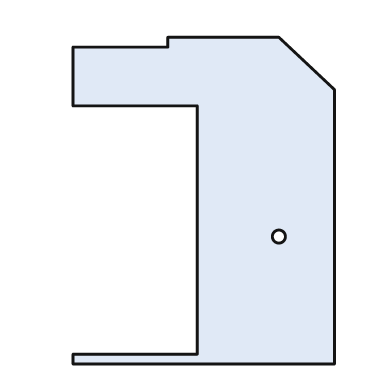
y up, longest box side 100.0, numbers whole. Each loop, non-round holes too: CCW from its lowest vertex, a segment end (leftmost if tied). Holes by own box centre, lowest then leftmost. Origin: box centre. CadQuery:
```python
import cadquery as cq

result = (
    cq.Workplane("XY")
    .moveTo(-40.0, -50.0)
    .lineTo(40.0, -50.0)
    .lineTo(40.0, 34.0)
    .lineTo(23.0, 50.0)
    .lineTo(-11.0, 50.0)
    .lineTo(-11.0, 47.0)
    .lineTo(-40.0, 47.0)
    .lineTo(-40.0, 29.0)
    .lineTo(-2.0, 29.0)
    .lineTo(-2.0, -47.0)
    .lineTo(-40.0, -47.0)
    .close()
    .moveTo(23.0, -11.0)
    .circle(2.0)
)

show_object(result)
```